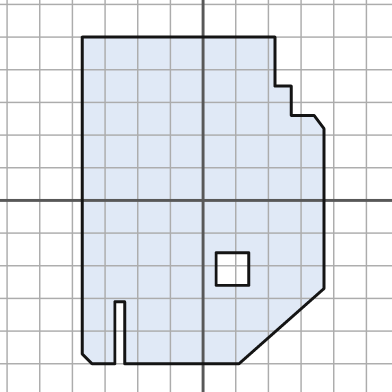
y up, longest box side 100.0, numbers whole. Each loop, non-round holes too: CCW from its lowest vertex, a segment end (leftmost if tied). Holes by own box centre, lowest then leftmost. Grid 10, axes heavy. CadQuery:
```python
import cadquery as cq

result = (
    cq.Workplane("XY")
    .moveTo(-34.0, -50.0)
    .lineTo(-27.0, -50.0)
    .lineTo(-27.0, -31.0)
    .lineTo(-24.0, -31.0)
    .lineTo(-24.0, -50.0)
    .lineTo(11.0, -50.0)
    .lineTo(37.0, -27.0)
    .lineTo(37.0, 22.0)
    .lineTo(34.0, 26.0)
    .lineTo(27.0, 26.0)
    .lineTo(27.0, 35.0)
    .lineTo(22.0, 35.0)
    .lineTo(22.0, 50.0)
    .lineTo(-37.0, 50.0)
    .lineTo(-37.0, -47.0)
    .close()
    .moveTo(4.0, -26.0)
    .lineTo(14.0, -26.0)
    .lineTo(14.0, -16.0)
    .lineTo(4.0, -16.0)
    .close()
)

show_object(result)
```